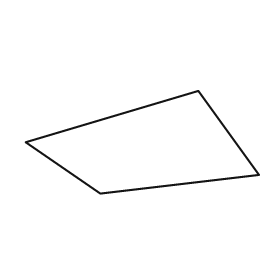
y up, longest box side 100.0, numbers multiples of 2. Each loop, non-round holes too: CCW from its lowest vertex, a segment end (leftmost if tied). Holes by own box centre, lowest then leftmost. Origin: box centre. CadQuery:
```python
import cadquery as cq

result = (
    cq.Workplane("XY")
    .moveTo(-18.0, -22.0)
    .lineTo(50.0, -14.0)
    .lineTo(24.0, 22.0)
    .lineTo(-50.0, 0.0)
    .close()
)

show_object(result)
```